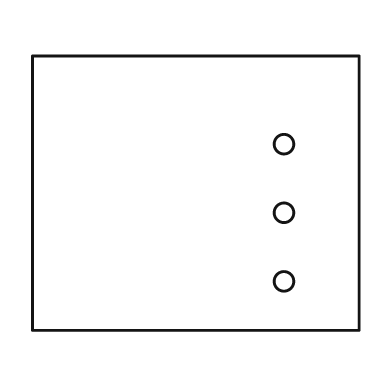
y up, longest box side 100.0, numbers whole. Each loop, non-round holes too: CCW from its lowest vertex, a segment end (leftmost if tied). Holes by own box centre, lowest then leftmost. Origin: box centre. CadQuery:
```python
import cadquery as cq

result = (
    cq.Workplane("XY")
    .moveTo(-50.0, -42.0)
    .lineTo(50.0, -42.0)
    .lineTo(50.0, 42.0)
    .lineTo(-50.0, 42.0)
    .close()
    .moveTo(27.0, -27.0)
    .circle(3.0)
    .moveTo(27.0, -6.0)
    .circle(3.0)
    .moveTo(27.0, 15.0)
    .circle(3.0)
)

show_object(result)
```